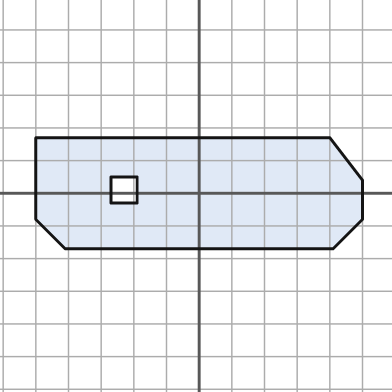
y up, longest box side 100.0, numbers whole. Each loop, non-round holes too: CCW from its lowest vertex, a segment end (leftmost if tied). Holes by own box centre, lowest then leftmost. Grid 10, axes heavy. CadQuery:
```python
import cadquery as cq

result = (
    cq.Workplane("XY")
    .moveTo(-41.0, -17.0)
    .lineTo(41.0, -17.0)
    .lineTo(50.0, -8.0)
    .lineTo(50.0, 4.0)
    .lineTo(40.0, 17.0)
    .lineTo(-50.0, 17.0)
    .lineTo(-50.0, -8.0)
    .close()
    .moveTo(-27.0, -3.0)
    .lineTo(-19.0, -3.0)
    .lineTo(-19.0, 5.0)
    .lineTo(-27.0, 5.0)
    .close()
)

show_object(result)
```